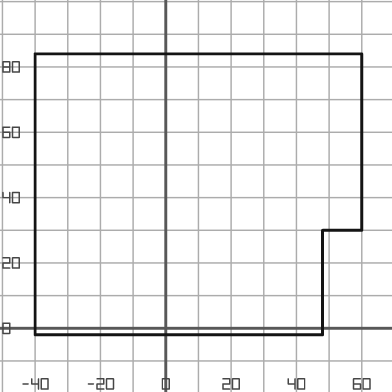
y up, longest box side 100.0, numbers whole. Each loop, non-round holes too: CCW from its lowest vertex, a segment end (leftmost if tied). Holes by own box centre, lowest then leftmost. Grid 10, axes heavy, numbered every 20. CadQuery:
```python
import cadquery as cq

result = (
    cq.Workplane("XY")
    .moveTo(-40.0, -2.0)
    .lineTo(48.0, -2.0)
    .lineTo(48.0, 30.0)
    .lineTo(60.0, 30.0)
    .lineTo(60.0, 84.0)
    .lineTo(-40.0, 84.0)
    .close()
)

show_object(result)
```